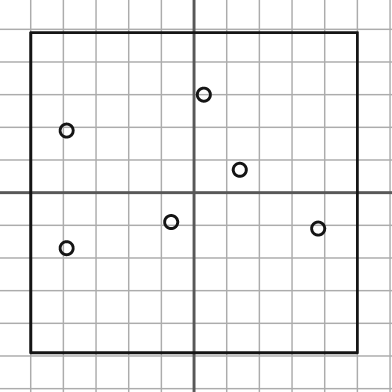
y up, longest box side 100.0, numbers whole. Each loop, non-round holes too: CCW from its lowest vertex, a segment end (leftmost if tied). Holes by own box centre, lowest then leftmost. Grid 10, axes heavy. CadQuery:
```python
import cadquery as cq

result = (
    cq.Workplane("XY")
    .moveTo(-50.0, -49.0)
    .lineTo(50.0, -49.0)
    .lineTo(50.0, 49.0)
    .lineTo(-50.0, 49.0)
    .close()
    .moveTo(-39.0, -17.0)
    .circle(2.0)
    .moveTo(38.0, -11.0)
    .circle(2.0)
    .moveTo(-7.0, -9.0)
    .circle(2.0)
    .moveTo(14.0, 7.0)
    .circle(2.0)
    .moveTo(-39.0, 19.0)
    .circle(2.0)
    .moveTo(3.0, 30.0)
    .circle(2.0)
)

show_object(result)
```